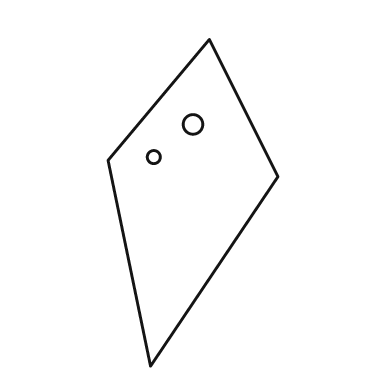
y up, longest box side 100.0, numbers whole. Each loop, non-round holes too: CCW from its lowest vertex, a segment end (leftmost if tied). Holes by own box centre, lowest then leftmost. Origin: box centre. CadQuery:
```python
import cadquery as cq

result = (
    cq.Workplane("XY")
    .moveTo(-13.0, -50.0)
    .lineTo(26.0, 8.0)
    .lineTo(5.0, 50.0)
    .lineTo(-26.0, 13.0)
    .close()
    .moveTo(-12.0, 14.0)
    .circle(2.0)
    .moveTo(0.0, 24.0)
    .circle(3.0)
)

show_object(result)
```